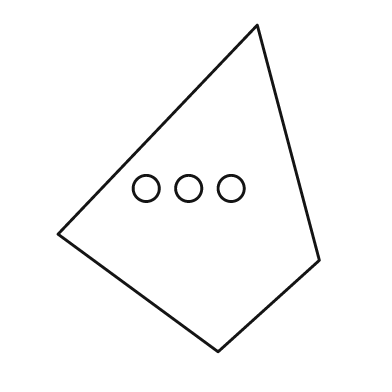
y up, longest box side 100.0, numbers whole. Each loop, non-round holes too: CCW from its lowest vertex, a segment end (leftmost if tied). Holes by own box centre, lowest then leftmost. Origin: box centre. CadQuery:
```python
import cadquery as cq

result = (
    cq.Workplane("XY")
    .moveTo(9.0, -50.0)
    .lineTo(40.0, -22.0)
    .lineTo(21.0, 50.0)
    .lineTo(-40.0, -14.0)
    .close()
    .moveTo(-13.0, 0.0)
    .circle(4.0)
    .moveTo(0.0, 0.0)
    .circle(4.0)
    .moveTo(13.0, 0.0)
    .circle(4.0)
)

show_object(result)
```